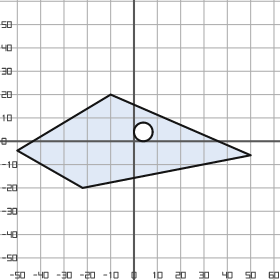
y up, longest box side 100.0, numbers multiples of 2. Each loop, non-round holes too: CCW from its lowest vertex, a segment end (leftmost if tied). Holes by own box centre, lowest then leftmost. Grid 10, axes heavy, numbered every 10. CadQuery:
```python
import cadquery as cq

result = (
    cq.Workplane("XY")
    .moveTo(-22.0, -20.0)
    .lineTo(50.0, -6.0)
    .lineTo(-10.0, 20.0)
    .lineTo(-50.0, -4.0)
    .close()
    .moveTo(4.0, 4.0)
    .circle(4.0)
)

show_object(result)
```